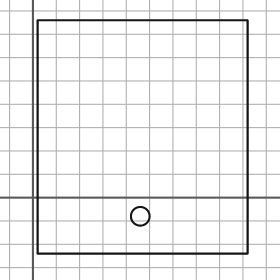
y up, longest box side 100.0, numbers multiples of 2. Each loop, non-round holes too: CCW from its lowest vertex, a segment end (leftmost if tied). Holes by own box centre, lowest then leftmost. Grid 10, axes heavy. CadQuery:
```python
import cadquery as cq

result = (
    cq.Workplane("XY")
    .moveTo(2.0, -24.0)
    .lineTo(92.0, -24.0)
    .lineTo(92.0, 76.0)
    .lineTo(2.0, 76.0)
    .close()
    .moveTo(46.0, -8.0)
    .circle(4.0)
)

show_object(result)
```